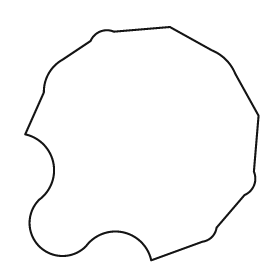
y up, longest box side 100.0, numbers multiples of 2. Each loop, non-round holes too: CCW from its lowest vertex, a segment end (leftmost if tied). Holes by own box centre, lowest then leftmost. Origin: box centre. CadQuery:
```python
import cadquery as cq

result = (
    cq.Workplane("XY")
    .moveTo(4.0, -50.0)
    .lineTo(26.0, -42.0)
    .threePointArc((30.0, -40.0), (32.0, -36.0))
    .lineTo(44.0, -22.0)
    .threePointArc((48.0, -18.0), (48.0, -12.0))
    .lineTo(50.0, 12.0)
    .lineTo(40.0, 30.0)
    .threePointArc((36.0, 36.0), (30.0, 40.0))
    .lineTo(12.0, 50.0)
    .lineTo(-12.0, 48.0)
    .threePointArc((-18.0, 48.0), (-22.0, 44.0))
    .lineTo(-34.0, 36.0)
    .threePointArc((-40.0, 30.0), (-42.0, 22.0))
    .lineTo(-50.0, 4.0)
    .threePointArc((-38.0, -8.0), (-44.0, -24.0))
    .threePointArc((-44.0, -44.0), (-24.0, -44.0))
    .threePointArc((-8.0, -38.0), (4.0, -50.0))
    .close()
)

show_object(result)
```